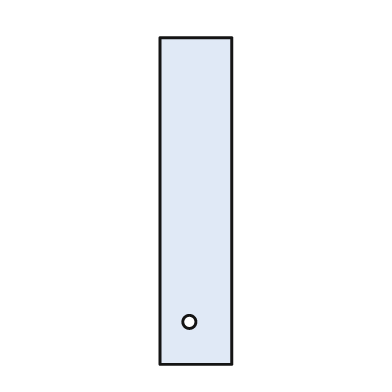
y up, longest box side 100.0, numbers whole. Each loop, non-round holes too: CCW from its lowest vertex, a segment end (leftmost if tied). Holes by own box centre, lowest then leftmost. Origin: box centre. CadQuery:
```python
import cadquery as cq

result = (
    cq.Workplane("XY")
    .moveTo(-11.0, -50.0)
    .lineTo(11.0, -50.0)
    .lineTo(11.0, 50.0)
    .lineTo(-11.0, 50.0)
    .close()
    .moveTo(-2.0, -37.0)
    .circle(2.0)
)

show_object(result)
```